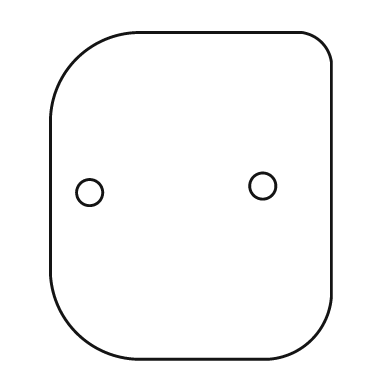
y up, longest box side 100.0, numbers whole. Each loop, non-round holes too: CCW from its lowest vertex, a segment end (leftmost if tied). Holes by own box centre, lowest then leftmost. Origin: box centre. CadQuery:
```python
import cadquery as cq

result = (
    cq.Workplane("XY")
    .moveTo(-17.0, -50.0)
    .lineTo(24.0, -50.0)
    .threePointArc((37.0, -44.0), (43.0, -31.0))
    .lineTo(43.0, 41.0)
    .threePointArc((40.0, 47.0), (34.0, 50.0))
    .lineTo(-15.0, 50.0)
    .threePointArc((-35.0, 42.0), (-43.0, 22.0))
    .lineTo(-43.0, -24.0)
    .threePointArc((-35.0, -42.0), (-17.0, -50.0))
    .close()
    .moveTo(-31.0, 1.0)
    .circle(4.0)
    .moveTo(22.0, 3.0)
    .circle(4.0)
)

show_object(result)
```